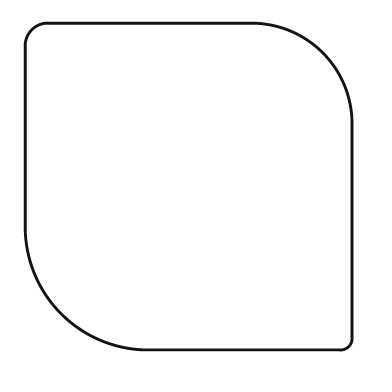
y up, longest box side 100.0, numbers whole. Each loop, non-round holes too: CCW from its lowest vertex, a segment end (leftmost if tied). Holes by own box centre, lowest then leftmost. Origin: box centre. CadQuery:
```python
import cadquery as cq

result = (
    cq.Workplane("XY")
    .moveTo(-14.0, -50.0)
    .lineTo(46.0, -50.0)
    .threePointArc((49.0, -49.0), (50.0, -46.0))
    .lineTo(50.0, 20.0)
    .threePointArc((41.0, 41.0), (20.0, 50.0))
    .lineTo(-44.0, 50.0)
    .threePointArc((-48.0, 48.0), (-50.0, 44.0))
    .lineTo(-50.0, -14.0)
    .threePointArc((-39.0, -39.0), (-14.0, -50.0))
    .close()
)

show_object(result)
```